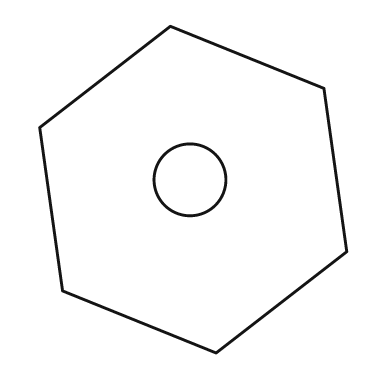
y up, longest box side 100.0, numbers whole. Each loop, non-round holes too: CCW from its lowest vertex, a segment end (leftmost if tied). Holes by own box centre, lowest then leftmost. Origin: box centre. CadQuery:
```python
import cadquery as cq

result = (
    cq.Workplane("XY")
    .moveTo(7.0, -50.0)
    .lineTo(47.0, -19.0)
    .lineTo(40.0, 31.0)
    .lineTo(-7.0, 50.0)
    .lineTo(-47.0, 19.0)
    .lineTo(-40.0, -31.0)
    .close()
    .moveTo(-1.0, 3.0)
    .circle(11.0)
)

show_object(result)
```